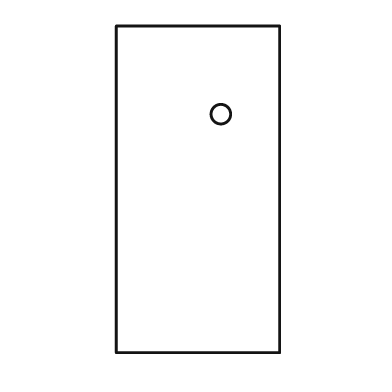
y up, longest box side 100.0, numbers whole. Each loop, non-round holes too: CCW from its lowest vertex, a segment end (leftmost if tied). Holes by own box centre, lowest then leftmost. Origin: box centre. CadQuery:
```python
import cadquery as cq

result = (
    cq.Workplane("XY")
    .moveTo(-25.0, -50.0)
    .lineTo(25.0, -50.0)
    .lineTo(25.0, 50.0)
    .lineTo(-25.0, 50.0)
    .close()
    .moveTo(7.0, 23.0)
    .circle(3.0)
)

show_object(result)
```